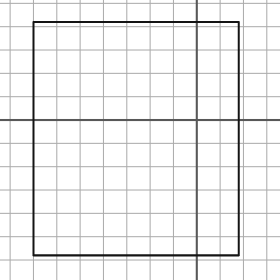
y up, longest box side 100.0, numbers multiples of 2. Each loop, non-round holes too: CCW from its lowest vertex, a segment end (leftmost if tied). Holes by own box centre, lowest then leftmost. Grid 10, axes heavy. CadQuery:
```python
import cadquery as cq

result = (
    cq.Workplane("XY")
    .moveTo(-70.0, -58.0)
    .lineTo(18.0, -58.0)
    .lineTo(18.0, 42.0)
    .lineTo(-70.0, 42.0)
    .close()
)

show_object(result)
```